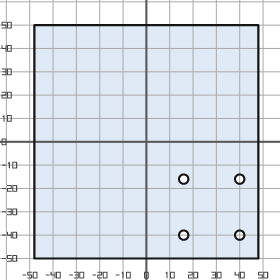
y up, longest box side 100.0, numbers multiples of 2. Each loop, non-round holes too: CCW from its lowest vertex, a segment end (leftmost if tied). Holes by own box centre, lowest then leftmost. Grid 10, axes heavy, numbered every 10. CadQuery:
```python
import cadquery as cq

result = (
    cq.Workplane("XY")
    .moveTo(-48.0, -50.0)
    .lineTo(48.0, -50.0)
    .lineTo(48.0, 50.0)
    .lineTo(-48.0, 50.0)
    .close()
    .moveTo(16.0, -40.0)
    .circle(2.0)
    .moveTo(40.0, -40.0)
    .circle(2.0)
    .moveTo(16.0, -16.0)
    .circle(2.0)
    .moveTo(40.0, -16.0)
    .circle(2.0)
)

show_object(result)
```